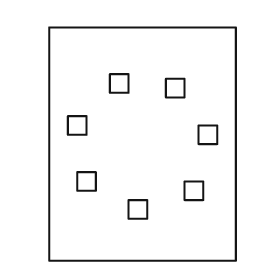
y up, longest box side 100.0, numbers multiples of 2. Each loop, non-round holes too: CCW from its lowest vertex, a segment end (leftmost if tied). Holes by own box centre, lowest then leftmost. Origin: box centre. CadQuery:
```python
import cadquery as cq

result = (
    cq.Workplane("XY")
    .moveTo(-40.0, -50.0)
    .lineTo(40.0, -50.0)
    .lineTo(40.0, 50.0)
    .lineTo(-40.0, 50.0)
    .close()
    .moveTo(-6.0, -32.0)
    .lineTo(2.0, -32.0)
    .lineTo(2.0, -24.0)
    .lineTo(-6.0, -24.0)
    .close()
    .moveTo(18.0, -24.0)
    .lineTo(26.0, -24.0)
    .lineTo(26.0, -16.0)
    .lineTo(18.0, -16.0)
    .close()
    .moveTo(-28.0, -20.0)
    .lineTo(-20.0, -20.0)
    .lineTo(-20.0, -12.0)
    .lineTo(-28.0, -12.0)
    .close()
    .moveTo(24.0, 0.0)
    .lineTo(32.0, 0.0)
    .lineTo(32.0, 8.0)
    .lineTo(24.0, 8.0)
    .close()
    .moveTo(-32.0, 4.0)
    .lineTo(-24.0, 4.0)
    .lineTo(-24.0, 12.0)
    .lineTo(-32.0, 12.0)
    .close()
    .moveTo(10.0, 20.0)
    .lineTo(18.0, 20.0)
    .lineTo(18.0, 28.0)
    .lineTo(10.0, 28.0)
    .close()
    .moveTo(-14.0, 22.0)
    .lineTo(-6.0, 22.0)
    .lineTo(-6.0, 30.0)
    .lineTo(-14.0, 30.0)
    .close()
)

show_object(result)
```